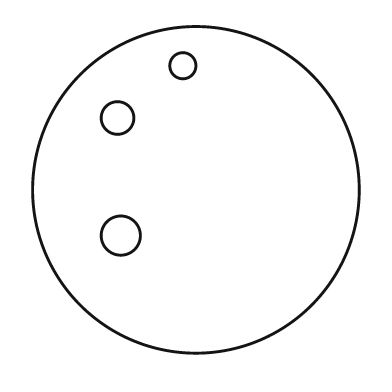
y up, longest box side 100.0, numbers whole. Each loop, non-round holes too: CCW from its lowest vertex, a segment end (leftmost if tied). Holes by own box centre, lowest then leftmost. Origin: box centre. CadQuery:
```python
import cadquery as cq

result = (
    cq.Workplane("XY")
    .moveTo(0.0, 0.0)
    .circle(50.0)
    .moveTo(-23.0, -14.0)
    .circle(6.0)
    .moveTo(-24.0, 22.0)
    .circle(5.0)
    .moveTo(-4.0, 38.0)
    .circle(4.0)
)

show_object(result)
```